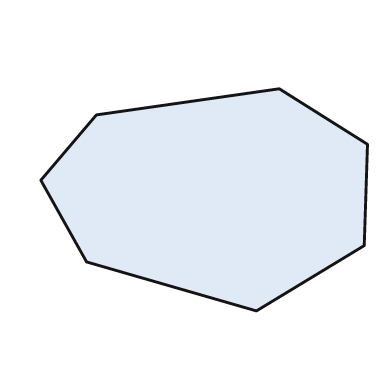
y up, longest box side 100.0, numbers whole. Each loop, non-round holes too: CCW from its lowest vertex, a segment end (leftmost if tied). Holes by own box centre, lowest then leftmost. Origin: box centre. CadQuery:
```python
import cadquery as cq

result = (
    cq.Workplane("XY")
    .moveTo(16.0, -34.0)
    .lineTo(49.0, -14.0)
    .lineTo(50.0, 17.0)
    .lineTo(23.0, 34.0)
    .lineTo(-33.0, 26.0)
    .lineTo(-50.0, 6.0)
    .lineTo(-36.0, -19.0)
    .close()
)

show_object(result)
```